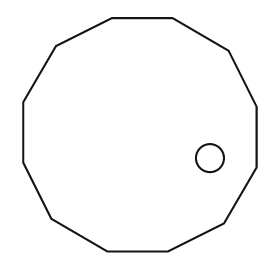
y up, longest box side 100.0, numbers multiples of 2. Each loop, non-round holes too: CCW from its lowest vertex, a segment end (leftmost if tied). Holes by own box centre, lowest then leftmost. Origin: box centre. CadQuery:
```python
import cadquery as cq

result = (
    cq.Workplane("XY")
    .moveTo(-14.0, -50.0)
    .lineTo(12.0, -50.0)
    .lineTo(36.0, -38.0)
    .lineTo(50.0, -14.0)
    .lineTo(50.0, 12.0)
    .lineTo(38.0, 36.0)
    .lineTo(14.0, 50.0)
    .lineTo(-12.0, 50.0)
    .lineTo(-36.0, 38.0)
    .lineTo(-50.0, 14.0)
    .lineTo(-50.0, -12.0)
    .lineTo(-38.0, -36.0)
    .close()
    .moveTo(30.0, -10.0)
    .circle(6.0)
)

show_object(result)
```